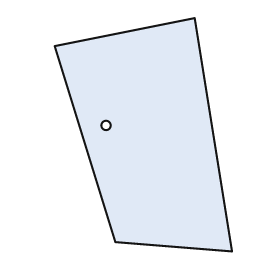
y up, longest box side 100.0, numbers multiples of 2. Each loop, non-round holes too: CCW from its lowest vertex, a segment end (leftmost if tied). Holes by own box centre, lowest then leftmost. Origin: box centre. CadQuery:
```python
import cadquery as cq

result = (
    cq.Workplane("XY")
    .moveTo(38.0, -50.0)
    .lineTo(22.0, 50.0)
    .lineTo(-38.0, 38.0)
    .lineTo(-12.0, -46.0)
    .close()
    .moveTo(-16.0, 4.0)
    .circle(2.0)
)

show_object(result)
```